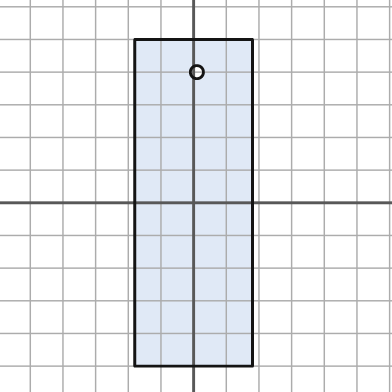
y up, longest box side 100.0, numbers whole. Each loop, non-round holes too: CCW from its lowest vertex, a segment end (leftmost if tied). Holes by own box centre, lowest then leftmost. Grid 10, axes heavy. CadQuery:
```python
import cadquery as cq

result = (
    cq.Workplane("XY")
    .moveTo(-18.0, -50.0)
    .lineTo(18.0, -50.0)
    .lineTo(18.0, 50.0)
    .lineTo(-18.0, 50.0)
    .close()
    .moveTo(1.0, 40.0)
    .circle(2.0)
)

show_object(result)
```